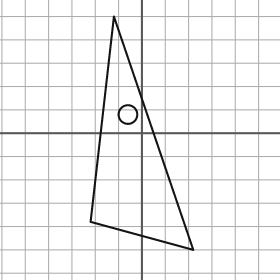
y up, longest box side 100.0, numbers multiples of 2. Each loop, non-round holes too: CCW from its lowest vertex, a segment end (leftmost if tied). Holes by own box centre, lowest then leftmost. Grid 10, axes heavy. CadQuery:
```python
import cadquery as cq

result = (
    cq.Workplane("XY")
    .moveTo(22.0, -50.0)
    .lineTo(-12.0, 50.0)
    .lineTo(-22.0, -38.0)
    .close()
    .moveTo(-6.0, 8.0)
    .circle(4.0)
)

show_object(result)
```